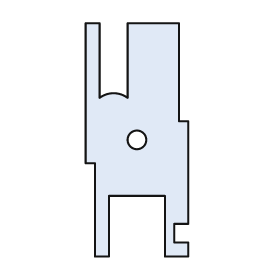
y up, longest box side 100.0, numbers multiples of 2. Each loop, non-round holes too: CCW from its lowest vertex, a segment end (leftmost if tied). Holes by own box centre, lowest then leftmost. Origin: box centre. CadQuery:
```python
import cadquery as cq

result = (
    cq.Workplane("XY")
    .moveTo(-18.0, -50.0)
    .lineTo(-12.0, -50.0)
    .lineTo(-12.0, -24.0)
    .lineTo(12.0, -24.0)
    .lineTo(12.0, -50.0)
    .lineTo(22.0, -50.0)
    .lineTo(22.0, -44.0)
    .lineTo(16.0, -44.0)
    .lineTo(16.0, -36.0)
    .lineTo(22.0, -36.0)
    .lineTo(22.0, 8.0)
    .lineTo(18.0, 8.0)
    .lineTo(18.0, 50.0)
    .lineTo(-4.0, 50.0)
    .lineTo(-4.0, 18.0)
    .threePointArc((-10.0, 20.0), (-16.0, 18.0))
    .lineTo(-16.0, 50.0)
    .lineTo(-22.0, 50.0)
    .lineTo(-22.0, -10.0)
    .lineTo(-18.0, -10.0)
    .close()
    .moveTo(0.0, 0.0)
    .circle(4.0)
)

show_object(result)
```